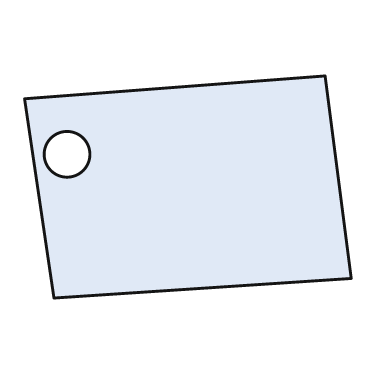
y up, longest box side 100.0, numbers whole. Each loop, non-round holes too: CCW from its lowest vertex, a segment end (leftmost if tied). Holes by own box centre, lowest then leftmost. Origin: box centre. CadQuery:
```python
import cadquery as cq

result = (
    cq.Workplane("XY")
    .moveTo(-41.0, -34.0)
    .lineTo(50.0, -28.0)
    .lineTo(42.0, 34.0)
    .lineTo(-50.0, 27.0)
    .close()
    .moveTo(-37.0, 10.0)
    .circle(7.0)
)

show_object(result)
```